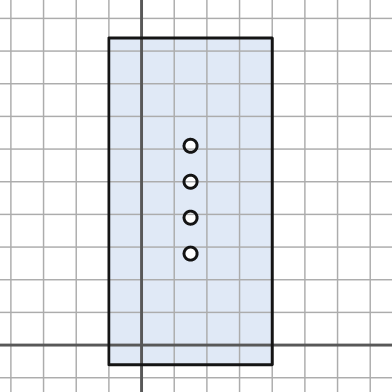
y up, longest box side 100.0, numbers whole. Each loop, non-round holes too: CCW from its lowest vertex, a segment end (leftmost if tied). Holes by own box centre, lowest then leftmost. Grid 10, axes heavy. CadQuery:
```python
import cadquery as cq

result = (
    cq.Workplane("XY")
    .moveTo(-10.0, -6.0)
    .lineTo(40.0, -6.0)
    .lineTo(40.0, 94.0)
    .lineTo(-10.0, 94.0)
    .close()
    .moveTo(15.0, 28.0)
    .circle(2.0)
    .moveTo(15.0, 39.0)
    .circle(2.0)
    .moveTo(15.0, 50.0)
    .circle(2.0)
    .moveTo(15.0, 61.0)
    .circle(2.0)
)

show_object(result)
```